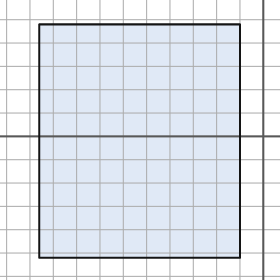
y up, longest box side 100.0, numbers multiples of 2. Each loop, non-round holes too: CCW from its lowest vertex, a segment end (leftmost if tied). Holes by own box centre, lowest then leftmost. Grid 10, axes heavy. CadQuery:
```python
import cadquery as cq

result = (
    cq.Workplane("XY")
    .moveTo(-96.0, -52.0)
    .lineTo(-10.0, -52.0)
    .lineTo(-10.0, 48.0)
    .lineTo(-96.0, 48.0)
    .close()
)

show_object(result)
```